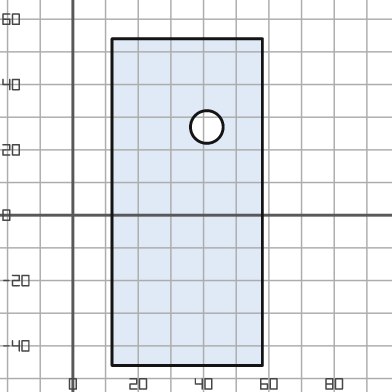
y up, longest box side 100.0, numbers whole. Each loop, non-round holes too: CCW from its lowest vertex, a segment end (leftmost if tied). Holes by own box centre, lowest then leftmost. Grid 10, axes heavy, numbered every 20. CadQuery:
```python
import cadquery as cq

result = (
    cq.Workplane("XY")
    .moveTo(12.0, -46.0)
    .lineTo(58.0, -46.0)
    .lineTo(58.0, 54.0)
    .lineTo(12.0, 54.0)
    .close()
    .moveTo(41.0, 27.0)
    .circle(5.0)
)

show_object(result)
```